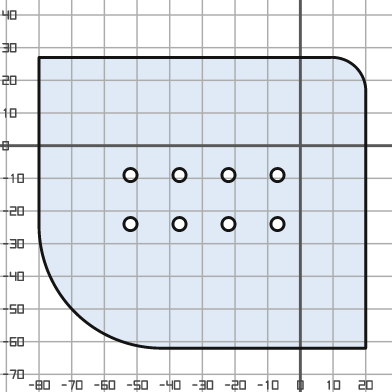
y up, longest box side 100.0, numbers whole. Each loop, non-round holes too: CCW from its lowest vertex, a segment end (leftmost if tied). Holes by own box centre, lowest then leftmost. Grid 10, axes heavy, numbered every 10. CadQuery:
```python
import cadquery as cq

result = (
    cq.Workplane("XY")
    .moveTo(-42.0, -62.0)
    .lineTo(20.0, -62.0)
    .lineTo(20.0, 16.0)
    .threePointArc((17.0, 24.0), (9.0, 27.0))
    .lineTo(-80.0, 27.0)
    .lineTo(-80.0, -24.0)
    .threePointArc((-69.0, -51.0), (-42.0, -62.0))
    .close()
    .moveTo(-52.0, -24.0)
    .circle(2.0)
    .moveTo(-37.0, -24.0)
    .circle(2.0)
    .moveTo(-22.0, -24.0)
    .circle(2.0)
    .moveTo(-7.0, -24.0)
    .circle(2.0)
    .moveTo(-52.0, -9.0)
    .circle(2.0)
    .moveTo(-37.0, -9.0)
    .circle(2.0)
    .moveTo(-22.0, -9.0)
    .circle(2.0)
    .moveTo(-7.0, -9.0)
    .circle(2.0)
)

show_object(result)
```